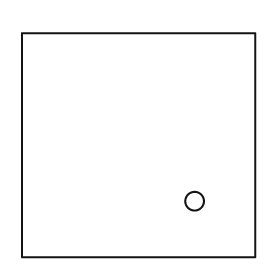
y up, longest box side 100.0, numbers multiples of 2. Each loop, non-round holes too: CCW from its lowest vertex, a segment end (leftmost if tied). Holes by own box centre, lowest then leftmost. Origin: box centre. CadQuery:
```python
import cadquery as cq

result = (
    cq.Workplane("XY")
    .moveTo(-50.0, -48.0)
    .lineTo(50.0, -48.0)
    .lineTo(50.0, 48.0)
    .lineTo(-50.0, 48.0)
    .close()
    .moveTo(24.0, -24.0)
    .circle(4.0)
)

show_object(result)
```